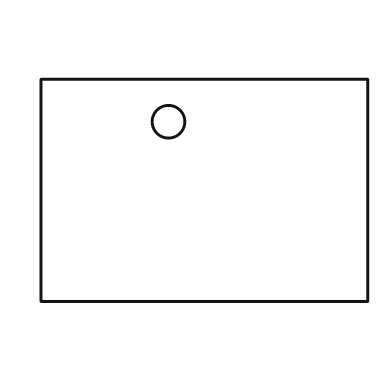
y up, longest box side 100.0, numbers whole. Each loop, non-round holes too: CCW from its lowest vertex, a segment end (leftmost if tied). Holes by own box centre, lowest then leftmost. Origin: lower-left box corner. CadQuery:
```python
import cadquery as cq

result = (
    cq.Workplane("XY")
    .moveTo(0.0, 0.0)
    .lineTo(100.0, 0.0)
    .lineTo(100.0, 68.0)
    .lineTo(0.0, 68.0)
    .close()
    .moveTo(39.0, 55.0)
    .circle(5.0)
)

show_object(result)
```